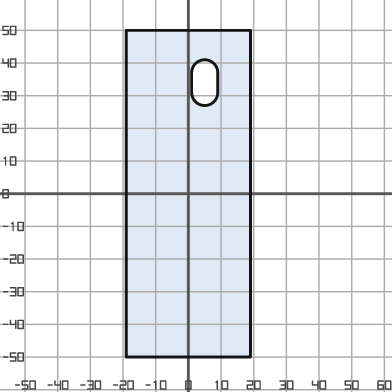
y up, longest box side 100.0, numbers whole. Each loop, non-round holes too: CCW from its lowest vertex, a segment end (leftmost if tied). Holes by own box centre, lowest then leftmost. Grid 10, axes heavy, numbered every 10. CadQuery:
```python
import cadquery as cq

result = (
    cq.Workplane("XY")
    .moveTo(-19.0, -50.0)
    .lineTo(19.0, -50.0)
    .lineTo(19.0, 50.0)
    .lineTo(-19.0, 50.0)
    .close()
    .moveTo(1.0, 31.0)
    .threePointArc((5.0, 27.0), (9.0, 31.0))
    .lineTo(9.0, 37.0)
    .threePointArc((5.0, 41.0), (1.0, 37.0))
    .close()
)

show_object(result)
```